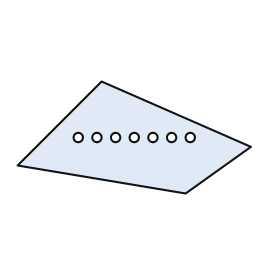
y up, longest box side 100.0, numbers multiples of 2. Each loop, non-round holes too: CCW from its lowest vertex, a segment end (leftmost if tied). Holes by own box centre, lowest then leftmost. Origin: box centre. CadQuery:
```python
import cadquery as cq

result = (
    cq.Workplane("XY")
    .moveTo(22.0, -24.0)
    .lineTo(50.0, -4.0)
    .lineTo(-14.0, 24.0)
    .lineTo(-50.0, -12.0)
    .close()
    .moveTo(-24.0, 0.0)
    .circle(2.0)
    .moveTo(-16.0, 0.0)
    .circle(2.0)
    .moveTo(-8.0, 0.0)
    .circle(2.0)
    .moveTo(0.0, 0.0)
    .circle(2.0)
    .moveTo(8.0, 0.0)
    .circle(2.0)
    .moveTo(16.0, 0.0)
    .circle(2.0)
    .moveTo(24.0, 0.0)
    .circle(2.0)
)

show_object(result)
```